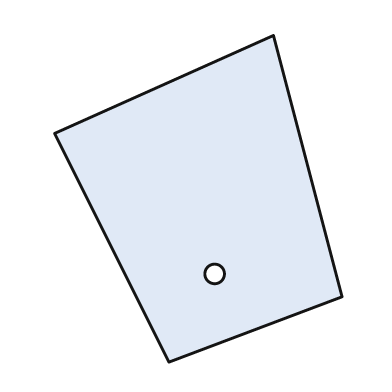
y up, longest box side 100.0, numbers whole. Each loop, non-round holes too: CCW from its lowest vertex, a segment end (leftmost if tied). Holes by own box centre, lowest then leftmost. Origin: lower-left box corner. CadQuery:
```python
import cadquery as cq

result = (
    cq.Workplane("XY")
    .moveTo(35.0, 0.0)
    .lineTo(88.0, 20.0)
    .lineTo(67.0, 100.0)
    .lineTo(0.0, 70.0)
    .close()
    .moveTo(49.0, 27.0)
    .circle(3.0)
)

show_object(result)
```